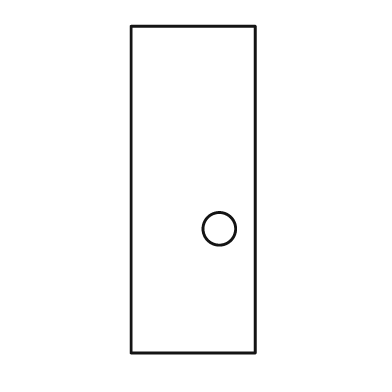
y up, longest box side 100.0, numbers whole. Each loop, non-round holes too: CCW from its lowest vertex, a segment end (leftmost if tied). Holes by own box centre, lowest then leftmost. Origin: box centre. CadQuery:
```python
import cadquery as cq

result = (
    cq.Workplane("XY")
    .moveTo(-19.0, -50.0)
    .lineTo(19.0, -50.0)
    .lineTo(19.0, 50.0)
    .lineTo(-19.0, 50.0)
    .close()
    .moveTo(8.0, -12.0)
    .circle(5.0)
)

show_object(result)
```